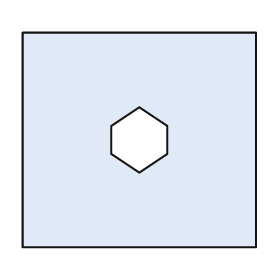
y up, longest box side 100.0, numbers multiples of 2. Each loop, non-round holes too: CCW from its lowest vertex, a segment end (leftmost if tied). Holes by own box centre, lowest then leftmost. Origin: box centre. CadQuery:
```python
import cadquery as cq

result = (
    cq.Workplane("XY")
    .moveTo(-50.0, -46.0)
    .lineTo(50.0, -46.0)
    .lineTo(50.0, 46.0)
    .lineTo(-50.0, 46.0)
    .close()
    .moveTo(0.0, -14.0)
    .lineTo(12.0, -6.0)
    .lineTo(12.0, 6.0)
    .lineTo(0.0, 14.0)
    .lineTo(-12.0, 6.0)
    .lineTo(-12.0, -6.0)
    .close()
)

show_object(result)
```